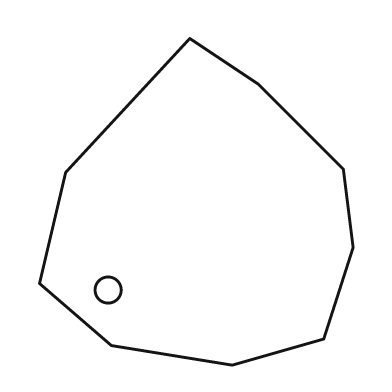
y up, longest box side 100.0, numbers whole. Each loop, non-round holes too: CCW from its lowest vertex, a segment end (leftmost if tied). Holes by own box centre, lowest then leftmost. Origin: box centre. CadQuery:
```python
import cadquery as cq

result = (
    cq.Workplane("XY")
    .moveTo(11.0, -50.0)
    .lineTo(39.0, -42.0)
    .lineTo(48.0, -14.0)
    .lineTo(45.0, 10.0)
    .lineTo(19.0, 36.0)
    .lineTo(-2.0, 50.0)
    .lineTo(-40.0, 9.0)
    .lineTo(-48.0, -25.0)
    .lineTo(-26.0, -44.0)
    .close()
    .moveTo(-27.0, -27.0)
    .circle(4.0)
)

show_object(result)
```